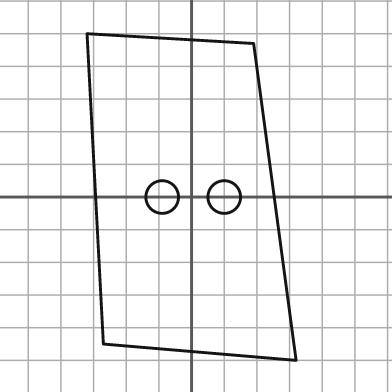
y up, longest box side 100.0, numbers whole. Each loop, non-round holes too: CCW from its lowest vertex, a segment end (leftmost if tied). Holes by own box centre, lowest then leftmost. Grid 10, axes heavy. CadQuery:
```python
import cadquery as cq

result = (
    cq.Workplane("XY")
    .moveTo(32.0, -50.0)
    .lineTo(19.0, 47.0)
    .lineTo(-32.0, 50.0)
    .lineTo(-27.0, -45.0)
    .close()
    .moveTo(-9.0, 0.0)
    .circle(5.0)
    .moveTo(10.0, 0.0)
    .circle(5.0)
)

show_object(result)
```